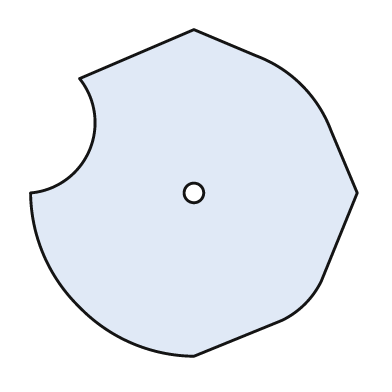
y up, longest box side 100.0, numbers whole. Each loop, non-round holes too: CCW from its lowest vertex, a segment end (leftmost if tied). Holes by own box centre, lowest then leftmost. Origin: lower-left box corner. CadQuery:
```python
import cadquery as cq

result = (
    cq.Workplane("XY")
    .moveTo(50.0, 0.0)
    .lineTo(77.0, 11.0)
    .threePointArc((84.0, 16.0), (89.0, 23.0))
    .lineTo(100.0, 50.0)
    .lineTo(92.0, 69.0)
    .threePointArc((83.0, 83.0), (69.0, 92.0))
    .lineTo(50.0, 100.0)
    .lineTo(15.0, 85.0)
    .threePointArc((18.0, 63.0), (0.0, 50.0))
    .threePointArc((4.0, 31.0), (15.0, 15.0))
    .threePointArc((31.0, 4.0), (50.0, 0.0))
    .close()
    .moveTo(50.0, 50.0)
    .circle(3.0)
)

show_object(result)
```